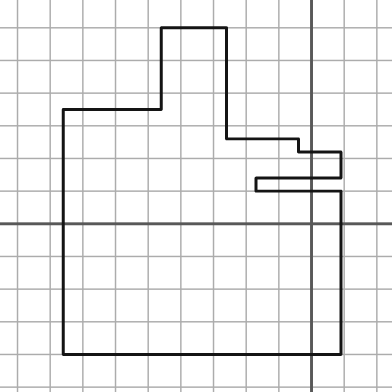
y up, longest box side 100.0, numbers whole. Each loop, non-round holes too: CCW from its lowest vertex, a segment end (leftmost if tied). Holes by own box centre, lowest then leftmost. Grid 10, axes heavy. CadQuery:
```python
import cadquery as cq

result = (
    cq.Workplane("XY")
    .moveTo(-76.0, -40.0)
    .lineTo(9.0, -40.0)
    .lineTo(9.0, 10.0)
    .lineTo(-17.0, 10.0)
    .lineTo(-17.0, 14.0)
    .lineTo(9.0, 14.0)
    .lineTo(9.0, 22.0)
    .lineTo(-4.0, 22.0)
    .lineTo(-4.0, 26.0)
    .lineTo(-26.0, 26.0)
    .lineTo(-26.0, 60.0)
    .lineTo(-46.0, 60.0)
    .lineTo(-46.0, 35.0)
    .lineTo(-76.0, 35.0)
    .close()
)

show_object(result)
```